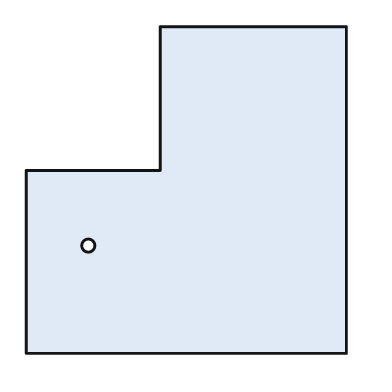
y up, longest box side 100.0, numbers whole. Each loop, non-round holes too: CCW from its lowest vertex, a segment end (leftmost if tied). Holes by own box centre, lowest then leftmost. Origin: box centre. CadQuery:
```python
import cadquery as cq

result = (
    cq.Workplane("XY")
    .moveTo(-49.0, -50.0)
    .lineTo(49.0, -50.0)
    .lineTo(49.0, 50.0)
    .lineTo(-8.0, 50.0)
    .lineTo(-8.0, 6.0)
    .lineTo(-49.0, 6.0)
    .close()
    .moveTo(-30.0, -17.0)
    .circle(2.0)
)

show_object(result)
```